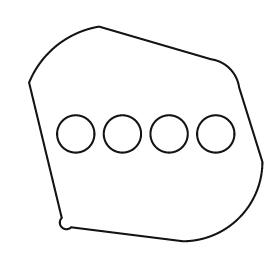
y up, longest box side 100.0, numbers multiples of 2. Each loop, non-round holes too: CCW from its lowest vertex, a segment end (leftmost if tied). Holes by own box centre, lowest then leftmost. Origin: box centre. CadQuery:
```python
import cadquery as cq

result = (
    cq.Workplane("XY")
    .moveTo(16.0, -46.0)
    .threePointArc((40.0, -36.0), (50.0, -12.0))
    .lineTo(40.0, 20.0)
    .threePointArc((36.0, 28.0), (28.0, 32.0))
    .lineTo(-20.0, 46.0)
    .threePointArc((-38.0, 38.0), (-50.0, 22.0))
    .lineTo(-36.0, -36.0)
    .threePointArc((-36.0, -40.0), (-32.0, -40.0))
    .close()
    .moveTo(-30.0, 0.0)
    .circle(8.0)
    .moveTo(-10.0, 0.0)
    .circle(8.0)
    .moveTo(10.0, 0.0)
    .circle(8.0)
    .moveTo(30.0, 0.0)
    .circle(8.0)
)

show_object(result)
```